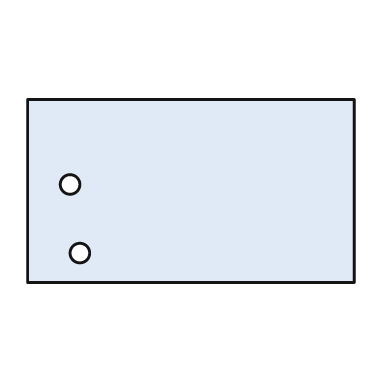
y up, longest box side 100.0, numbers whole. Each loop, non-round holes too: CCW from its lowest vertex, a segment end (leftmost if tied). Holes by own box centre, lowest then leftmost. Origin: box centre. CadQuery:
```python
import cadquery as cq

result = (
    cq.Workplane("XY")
    .moveTo(-50.0, -28.0)
    .lineTo(50.0, -28.0)
    .lineTo(50.0, 28.0)
    .lineTo(-50.0, 28.0)
    .close()
    .moveTo(-34.0, -19.0)
    .circle(3.0)
    .moveTo(-37.0, 2.0)
    .circle(3.0)
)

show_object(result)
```